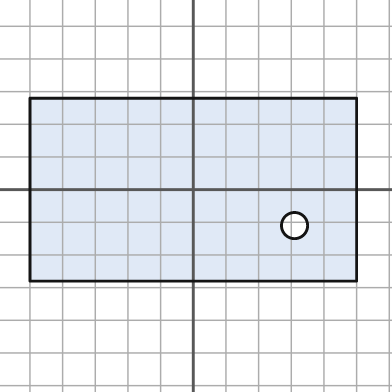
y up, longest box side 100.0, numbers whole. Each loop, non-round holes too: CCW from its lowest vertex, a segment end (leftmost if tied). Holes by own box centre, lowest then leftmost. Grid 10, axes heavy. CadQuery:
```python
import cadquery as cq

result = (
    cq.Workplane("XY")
    .moveTo(-50.0, -28.0)
    .lineTo(50.0, -28.0)
    .lineTo(50.0, 28.0)
    .lineTo(-50.0, 28.0)
    .close()
    .moveTo(31.0, -11.0)
    .circle(4.0)
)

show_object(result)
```